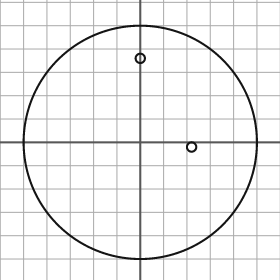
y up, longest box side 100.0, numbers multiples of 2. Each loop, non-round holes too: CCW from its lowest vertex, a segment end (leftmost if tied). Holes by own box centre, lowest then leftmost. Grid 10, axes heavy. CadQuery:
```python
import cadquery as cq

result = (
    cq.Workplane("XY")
    .moveTo(0.0, 0.0)
    .circle(50.0)
    .moveTo(22.0, -2.0)
    .circle(2.0)
    .moveTo(0.0, 36.0)
    .circle(2.0)
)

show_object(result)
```